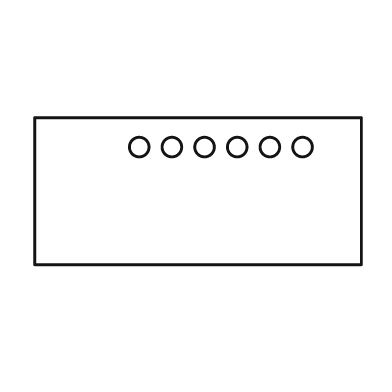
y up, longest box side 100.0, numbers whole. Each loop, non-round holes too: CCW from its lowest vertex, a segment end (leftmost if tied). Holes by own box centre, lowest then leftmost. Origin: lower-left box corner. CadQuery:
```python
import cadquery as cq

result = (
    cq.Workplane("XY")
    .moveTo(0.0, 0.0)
    .lineTo(100.0, 0.0)
    .lineTo(100.0, 45.0)
    .lineTo(0.0, 45.0)
    .close()
    .moveTo(32.0, 36.0)
    .circle(3.0)
    .moveTo(42.0, 36.0)
    .circle(3.0)
    .moveTo(52.0, 36.0)
    .circle(3.0)
    .moveTo(62.0, 36.0)
    .circle(3.0)
    .moveTo(72.0, 36.0)
    .circle(3.0)
    .moveTo(82.0, 36.0)
    .circle(3.0)
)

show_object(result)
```